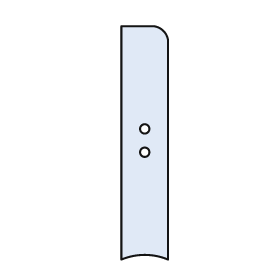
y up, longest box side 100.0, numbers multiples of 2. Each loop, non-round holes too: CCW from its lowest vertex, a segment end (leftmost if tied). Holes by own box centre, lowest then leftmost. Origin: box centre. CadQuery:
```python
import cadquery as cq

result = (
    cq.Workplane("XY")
    .moveTo(-10.0, -50.0)
    .threePointArc((0.0, -48.0), (10.0, -50.0))
    .lineTo(10.0, 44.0)
    .threePointArc((8.0, 48.0), (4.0, 50.0))
    .lineTo(-10.0, 50.0)
    .close()
    .moveTo(0.0, -4.0)
    .circle(2.0)
    .moveTo(0.0, 6.0)
    .circle(2.0)
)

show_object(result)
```